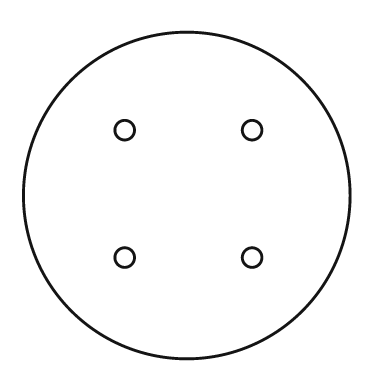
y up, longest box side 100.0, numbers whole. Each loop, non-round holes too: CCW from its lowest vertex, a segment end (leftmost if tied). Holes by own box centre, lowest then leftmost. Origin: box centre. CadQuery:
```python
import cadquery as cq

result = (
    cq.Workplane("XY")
    .moveTo(0.0, 0.0)
    .circle(50.0)
    .moveTo(-19.0, -19.0)
    .circle(3.0)
    .moveTo(20.0, -19.0)
    .circle(3.0)
    .moveTo(-19.0, 20.0)
    .circle(3.0)
    .moveTo(20.0, 20.0)
    .circle(3.0)
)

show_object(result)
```